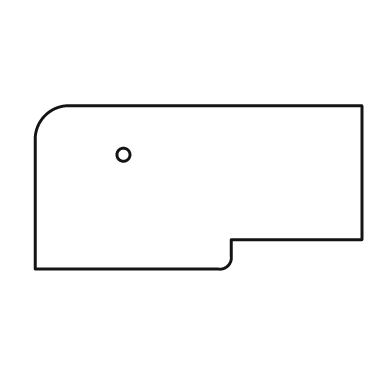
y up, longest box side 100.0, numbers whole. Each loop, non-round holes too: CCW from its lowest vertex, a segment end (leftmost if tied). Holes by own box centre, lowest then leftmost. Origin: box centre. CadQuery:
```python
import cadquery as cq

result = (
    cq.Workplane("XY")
    .moveTo(-50.0, -25.0)
    .lineTo(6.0, -25.0)
    .threePointArc((9.0, -24.0), (10.0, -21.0))
    .lineTo(10.0, -16.0)
    .lineTo(50.0, -16.0)
    .lineTo(50.0, 25.0)
    .lineTo(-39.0, 25.0)
    .threePointArc((-47.0, 22.0), (-50.0, 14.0))
    .close()
    .moveTo(-23.0, 10.0)
    .circle(2.0)
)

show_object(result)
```